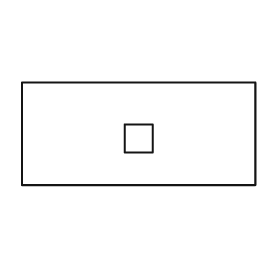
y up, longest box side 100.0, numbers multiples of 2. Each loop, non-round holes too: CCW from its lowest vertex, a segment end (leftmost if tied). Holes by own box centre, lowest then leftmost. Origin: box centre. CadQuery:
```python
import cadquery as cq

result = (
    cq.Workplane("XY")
    .moveTo(-50.0, -22.0)
    .lineTo(50.0, -22.0)
    .lineTo(50.0, 22.0)
    .lineTo(-50.0, 22.0)
    .close()
    .moveTo(-6.0, -8.0)
    .lineTo(6.0, -8.0)
    .lineTo(6.0, 4.0)
    .lineTo(-6.0, 4.0)
    .close()
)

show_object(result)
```